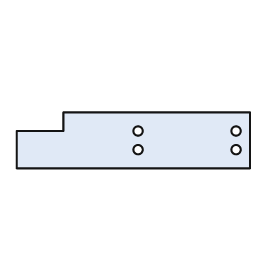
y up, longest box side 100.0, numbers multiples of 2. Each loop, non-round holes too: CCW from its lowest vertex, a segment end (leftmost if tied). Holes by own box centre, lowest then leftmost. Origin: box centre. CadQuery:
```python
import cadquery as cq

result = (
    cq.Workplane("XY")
    .moveTo(-50.0, -12.0)
    .lineTo(50.0, -12.0)
    .lineTo(50.0, 12.0)
    .lineTo(-30.0, 12.0)
    .lineTo(-30.0, 4.0)
    .lineTo(-50.0, 4.0)
    .close()
    .moveTo(2.0, -4.0)
    .circle(2.0)
    .moveTo(44.0, -4.0)
    .circle(2.0)
    .moveTo(2.0, 4.0)
    .circle(2.0)
    .moveTo(44.0, 4.0)
    .circle(2.0)
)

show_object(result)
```